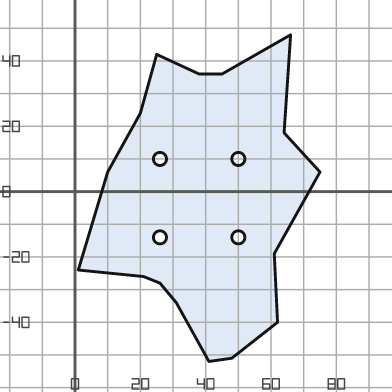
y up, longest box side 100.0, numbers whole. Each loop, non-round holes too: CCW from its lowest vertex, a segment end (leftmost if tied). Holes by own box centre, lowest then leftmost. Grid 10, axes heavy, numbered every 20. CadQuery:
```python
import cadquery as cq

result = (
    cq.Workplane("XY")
    .moveTo(41.0, -52.0)
    .lineTo(48.0, -51.0)
    .lineTo(62.0, -40.0)
    .lineTo(61.0, -19.0)
    .lineTo(75.0, 6.0)
    .lineTo(64.0, 18.0)
    .lineTo(66.0, 48.0)
    .lineTo(45.0, 36.0)
    .lineTo(38.0, 36.0)
    .lineTo(25.0, 42.0)
    .lineTo(20.0, 24.0)
    .lineTo(10.0, 6.0)
    .lineTo(1.0, -24.0)
    .lineTo(21.0, -26.0)
    .lineTo(26.0, -28.0)
    .lineTo(31.0, -34.0)
    .close()
    .moveTo(26.0, -14.0)
    .circle(2.0)
    .moveTo(50.0, -14.0)
    .circle(2.0)
    .moveTo(26.0, 10.0)
    .circle(2.0)
    .moveTo(50.0, 10.0)
    .circle(2.0)
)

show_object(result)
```